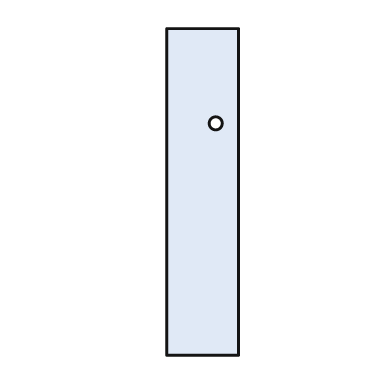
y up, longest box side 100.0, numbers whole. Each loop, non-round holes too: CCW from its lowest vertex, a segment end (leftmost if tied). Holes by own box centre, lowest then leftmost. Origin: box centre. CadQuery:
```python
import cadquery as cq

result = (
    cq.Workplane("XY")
    .moveTo(-11.0, -50.0)
    .lineTo(11.0, -50.0)
    .lineTo(11.0, 50.0)
    .lineTo(-11.0, 50.0)
    .close()
    .moveTo(4.0, 21.0)
    .circle(2.0)
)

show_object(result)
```